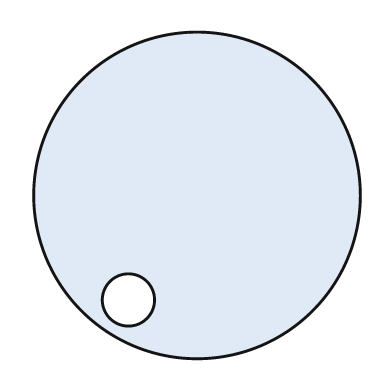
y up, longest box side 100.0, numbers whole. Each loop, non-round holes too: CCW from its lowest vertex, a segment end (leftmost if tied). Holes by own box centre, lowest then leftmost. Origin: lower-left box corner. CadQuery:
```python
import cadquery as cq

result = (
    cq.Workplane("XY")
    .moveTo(50.0, 50.0)
    .circle(50.0)
    .moveTo(29.0, 18.0)
    .circle(8.0)
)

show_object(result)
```